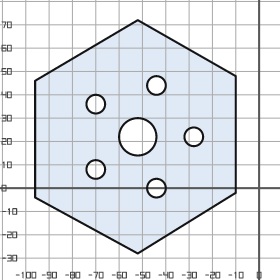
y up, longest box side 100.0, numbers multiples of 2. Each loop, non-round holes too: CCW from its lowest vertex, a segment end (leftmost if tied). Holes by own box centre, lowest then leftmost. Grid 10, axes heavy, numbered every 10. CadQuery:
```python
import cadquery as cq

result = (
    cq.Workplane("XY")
    .moveTo(-52.0, -28.0)
    .lineTo(-10.0, -2.0)
    .lineTo(-10.0, 48.0)
    .lineTo(-52.0, 72.0)
    .lineTo(-96.0, 46.0)
    .lineTo(-96.0, -4.0)
    .close()
    .moveTo(-44.0, 0.0)
    .circle(4.0)
    .moveTo(-70.0, 8.0)
    .circle(4.0)
    .moveTo(-52.0, 22.0)
    .circle(8.0)
    .moveTo(-28.0, 22.0)
    .circle(4.0)
    .moveTo(-70.0, 36.0)
    .circle(4.0)
    .moveTo(-44.0, 44.0)
    .circle(4.0)
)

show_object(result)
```